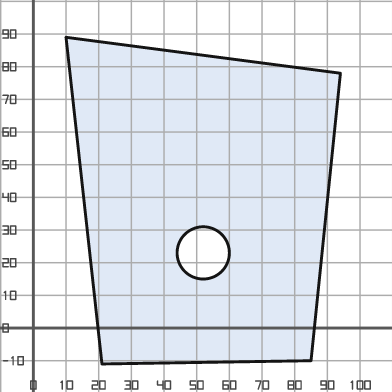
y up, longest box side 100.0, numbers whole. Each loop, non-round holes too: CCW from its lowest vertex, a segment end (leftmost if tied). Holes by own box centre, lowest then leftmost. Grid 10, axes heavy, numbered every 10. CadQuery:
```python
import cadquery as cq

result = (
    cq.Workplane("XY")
    .moveTo(21.0, -11.0)
    .lineTo(85.0, -10.0)
    .lineTo(94.0, 78.0)
    .lineTo(10.0, 89.0)
    .close()
    .moveTo(52.0, 23.0)
    .circle(8.0)
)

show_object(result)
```